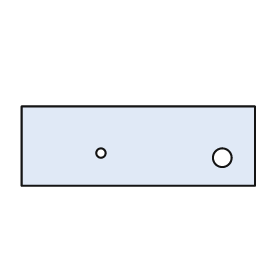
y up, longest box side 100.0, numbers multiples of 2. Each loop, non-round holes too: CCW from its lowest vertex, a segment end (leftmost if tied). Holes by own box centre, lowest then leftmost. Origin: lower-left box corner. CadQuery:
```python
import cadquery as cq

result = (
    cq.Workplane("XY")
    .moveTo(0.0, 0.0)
    .lineTo(100.0, 0.0)
    .lineTo(100.0, 34.0)
    .lineTo(0.0, 34.0)
    .close()
    .moveTo(86.0, 12.0)
    .circle(4.0)
    .moveTo(34.0, 14.0)
    .circle(2.0)
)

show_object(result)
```